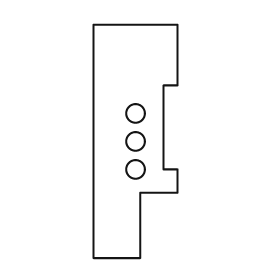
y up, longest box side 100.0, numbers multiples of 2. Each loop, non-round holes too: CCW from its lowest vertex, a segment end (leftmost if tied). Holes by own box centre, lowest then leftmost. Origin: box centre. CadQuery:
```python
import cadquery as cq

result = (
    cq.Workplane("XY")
    .moveTo(-18.0, -50.0)
    .lineTo(2.0, -50.0)
    .lineTo(2.0, -22.0)
    .lineTo(18.0, -22.0)
    .lineTo(18.0, -12.0)
    .lineTo(12.0, -12.0)
    .lineTo(12.0, 24.0)
    .lineTo(18.0, 24.0)
    .lineTo(18.0, 50.0)
    .lineTo(-18.0, 50.0)
    .close()
    .moveTo(0.0, -12.0)
    .circle(4.0)
    .moveTo(0.0, 0.0)
    .circle(4.0)
    .moveTo(0.0, 12.0)
    .circle(4.0)
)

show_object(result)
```